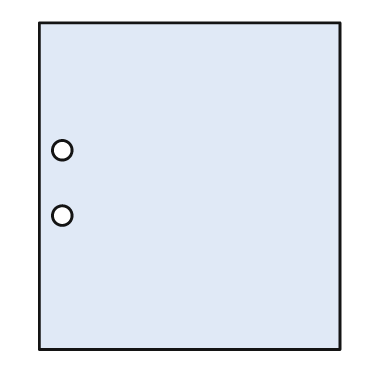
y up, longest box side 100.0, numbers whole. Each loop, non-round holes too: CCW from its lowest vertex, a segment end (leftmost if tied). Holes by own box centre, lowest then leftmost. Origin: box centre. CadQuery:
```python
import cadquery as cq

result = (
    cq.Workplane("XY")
    .moveTo(-46.0, -50.0)
    .lineTo(46.0, -50.0)
    .lineTo(46.0, 50.0)
    .lineTo(-46.0, 50.0)
    .close()
    .moveTo(-39.0, -9.0)
    .circle(3.0)
    .moveTo(-39.0, 11.0)
    .circle(3.0)
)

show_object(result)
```